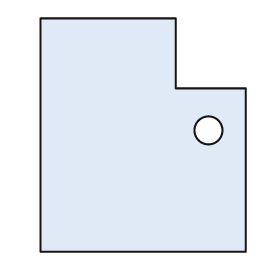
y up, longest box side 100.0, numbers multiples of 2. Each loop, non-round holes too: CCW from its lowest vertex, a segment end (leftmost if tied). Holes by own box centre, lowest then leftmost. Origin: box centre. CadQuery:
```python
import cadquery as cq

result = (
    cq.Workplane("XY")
    .moveTo(-44.0, -50.0)
    .lineTo(44.0, -50.0)
    .lineTo(44.0, 20.0)
    .lineTo(14.0, 20.0)
    .lineTo(14.0, 50.0)
    .lineTo(-44.0, 50.0)
    .close()
    .moveTo(28.0, 2.0)
    .circle(6.0)
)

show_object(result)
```